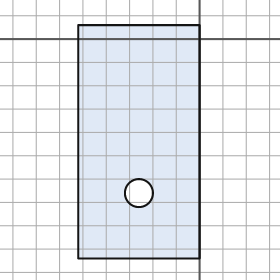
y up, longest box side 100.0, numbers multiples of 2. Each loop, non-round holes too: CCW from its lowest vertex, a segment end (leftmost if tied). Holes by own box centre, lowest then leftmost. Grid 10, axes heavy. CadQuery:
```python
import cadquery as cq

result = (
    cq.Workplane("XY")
    .moveTo(-52.0, -94.0)
    .lineTo(0.0, -94.0)
    .lineTo(0.0, 6.0)
    .lineTo(-52.0, 6.0)
    .close()
    .moveTo(-26.0, -66.0)
    .circle(6.0)
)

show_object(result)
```